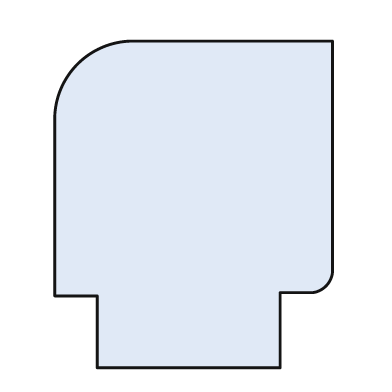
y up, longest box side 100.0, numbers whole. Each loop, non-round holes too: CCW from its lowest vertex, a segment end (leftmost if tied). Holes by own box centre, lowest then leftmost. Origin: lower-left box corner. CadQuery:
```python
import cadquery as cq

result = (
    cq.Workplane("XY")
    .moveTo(13.0, 0.0)
    .lineTo(69.0, 0.0)
    .lineTo(69.0, 23.0)
    .lineTo(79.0, 23.0)
    .threePointArc((83.0, 25.0), (85.0, 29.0))
    .lineTo(85.0, 100.0)
    .lineTo(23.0, 100.0)
    .threePointArc((7.0, 93.0), (0.0, 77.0))
    .lineTo(0.0, 22.0)
    .lineTo(13.0, 22.0)
    .close()
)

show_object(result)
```